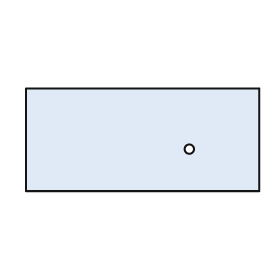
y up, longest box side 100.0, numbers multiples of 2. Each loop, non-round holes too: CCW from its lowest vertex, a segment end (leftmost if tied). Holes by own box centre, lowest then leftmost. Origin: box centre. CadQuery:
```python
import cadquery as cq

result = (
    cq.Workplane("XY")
    .moveTo(-50.0, -22.0)
    .lineTo(50.0, -22.0)
    .lineTo(50.0, 22.0)
    .lineTo(-50.0, 22.0)
    .close()
    .moveTo(20.0, -4.0)
    .circle(2.0)
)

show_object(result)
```